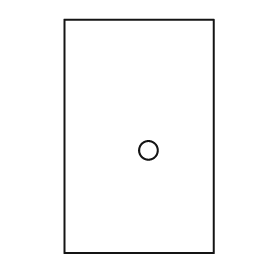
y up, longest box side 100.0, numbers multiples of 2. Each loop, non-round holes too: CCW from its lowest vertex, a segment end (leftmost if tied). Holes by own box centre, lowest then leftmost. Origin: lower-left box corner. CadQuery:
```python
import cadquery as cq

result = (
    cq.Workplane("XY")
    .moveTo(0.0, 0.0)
    .lineTo(64.0, 0.0)
    .lineTo(64.0, 100.0)
    .lineTo(0.0, 100.0)
    .close()
    .moveTo(36.0, 44.0)
    .circle(4.0)
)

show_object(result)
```